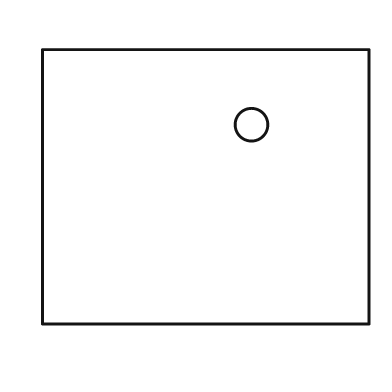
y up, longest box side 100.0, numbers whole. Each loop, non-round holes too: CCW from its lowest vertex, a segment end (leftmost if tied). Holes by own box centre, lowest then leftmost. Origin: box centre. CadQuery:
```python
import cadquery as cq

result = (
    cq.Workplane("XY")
    .moveTo(-50.0, -42.0)
    .lineTo(50.0, -42.0)
    .lineTo(50.0, 42.0)
    .lineTo(-50.0, 42.0)
    .close()
    .moveTo(14.0, 19.0)
    .circle(5.0)
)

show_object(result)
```